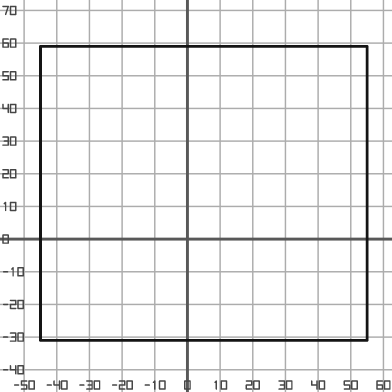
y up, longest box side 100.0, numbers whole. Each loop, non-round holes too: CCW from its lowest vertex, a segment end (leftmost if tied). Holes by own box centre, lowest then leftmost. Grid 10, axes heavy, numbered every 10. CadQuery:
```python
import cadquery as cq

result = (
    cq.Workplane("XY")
    .moveTo(-45.0, -31.0)
    .lineTo(55.0, -31.0)
    .lineTo(55.0, 59.0)
    .lineTo(-45.0, 59.0)
    .close()
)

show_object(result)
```